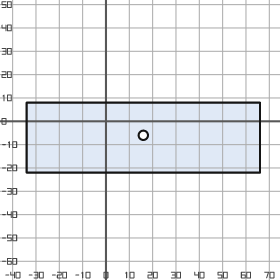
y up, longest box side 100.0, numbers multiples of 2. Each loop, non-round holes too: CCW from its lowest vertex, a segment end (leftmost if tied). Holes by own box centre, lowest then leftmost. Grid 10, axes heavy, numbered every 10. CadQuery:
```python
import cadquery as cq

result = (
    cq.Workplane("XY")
    .moveTo(-34.0, -22.0)
    .lineTo(66.0, -22.0)
    .lineTo(66.0, 8.0)
    .lineTo(-34.0, 8.0)
    .close()
    .moveTo(16.0, -6.0)
    .circle(2.0)
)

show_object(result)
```